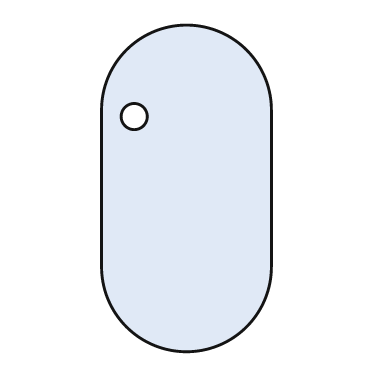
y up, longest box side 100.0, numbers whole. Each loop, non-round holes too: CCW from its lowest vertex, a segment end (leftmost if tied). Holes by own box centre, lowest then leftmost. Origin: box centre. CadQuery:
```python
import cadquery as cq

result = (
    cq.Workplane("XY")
    .moveTo(-26.0, -24.0)
    .threePointArc((0.0, -50.0), (26.0, -24.0))
    .lineTo(26.0, 24.0)
    .threePointArc((0.0, 50.0), (-26.0, 24.0))
    .close()
    .moveTo(-16.0, 22.0)
    .circle(4.0)
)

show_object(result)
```